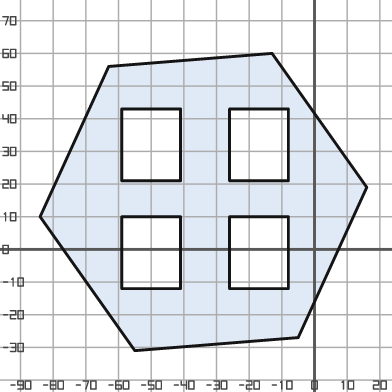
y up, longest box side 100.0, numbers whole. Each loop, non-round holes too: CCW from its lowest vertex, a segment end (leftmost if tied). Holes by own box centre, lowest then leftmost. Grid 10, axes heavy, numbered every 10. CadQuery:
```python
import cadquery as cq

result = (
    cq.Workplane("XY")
    .moveTo(-55.0, -31.0)
    .lineTo(-5.0, -27.0)
    .lineTo(16.0, 19.0)
    .lineTo(-13.0, 60.0)
    .lineTo(-63.0, 56.0)
    .lineTo(-84.0, 10.0)
    .close()
    .moveTo(-59.0, -12.0)
    .lineTo(-41.0, -12.0)
    .lineTo(-41.0, 10.0)
    .lineTo(-59.0, 10.0)
    .close()
    .moveTo(-26.0, -12.0)
    .lineTo(-8.0, -12.0)
    .lineTo(-8.0, 10.0)
    .lineTo(-26.0, 10.0)
    .close()
    .moveTo(-59.0, 21.0)
    .lineTo(-41.0, 21.0)
    .lineTo(-41.0, 43.0)
    .lineTo(-59.0, 43.0)
    .close()
    .moveTo(-26.0, 21.0)
    .lineTo(-8.0, 21.0)
    .lineTo(-8.0, 43.0)
    .lineTo(-26.0, 43.0)
    .close()
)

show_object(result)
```